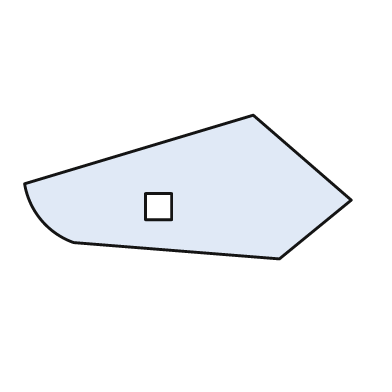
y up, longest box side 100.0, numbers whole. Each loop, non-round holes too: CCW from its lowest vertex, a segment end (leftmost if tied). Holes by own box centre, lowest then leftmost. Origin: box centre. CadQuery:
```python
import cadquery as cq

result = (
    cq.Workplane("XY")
    .moveTo(28.0, -22.0)
    .lineTo(50.0, -4.0)
    .lineTo(20.0, 22.0)
    .lineTo(-50.0, 1.0)
    .threePointArc((-45.0, -10.0), (-35.0, -17.0))
    .close()
    .moveTo(-13.0, -10.0)
    .lineTo(-5.0, -10.0)
    .lineTo(-5.0, -2.0)
    .lineTo(-13.0, -2.0)
    .close()
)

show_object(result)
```